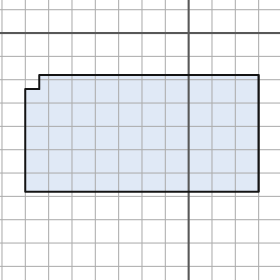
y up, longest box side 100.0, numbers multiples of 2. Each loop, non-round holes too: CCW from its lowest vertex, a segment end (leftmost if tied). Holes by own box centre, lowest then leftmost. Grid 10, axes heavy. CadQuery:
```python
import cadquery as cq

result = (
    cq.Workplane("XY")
    .moveTo(-70.0, -68.0)
    .lineTo(30.0, -68.0)
    .lineTo(30.0, -18.0)
    .lineTo(-64.0, -18.0)
    .lineTo(-64.0, -24.0)
    .lineTo(-70.0, -24.0)
    .close()
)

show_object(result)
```